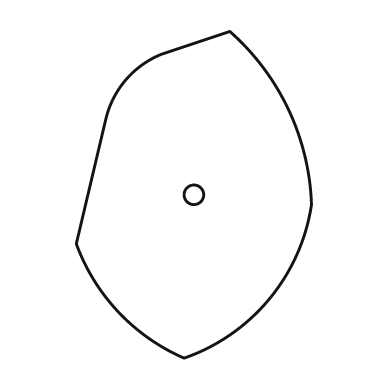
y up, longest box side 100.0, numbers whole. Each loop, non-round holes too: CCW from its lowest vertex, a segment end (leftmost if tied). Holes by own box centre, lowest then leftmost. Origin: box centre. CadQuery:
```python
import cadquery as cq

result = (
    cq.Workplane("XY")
    .moveTo(-3.0, -50.0)
    .threePointArc((23.0, -32.0), (36.0, -3.0))
    .threePointArc((29.0, 26.0), (11.0, 50.0))
    .lineTo(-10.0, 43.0)
    .threePointArc((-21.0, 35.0), (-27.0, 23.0))
    .lineTo(-36.0, -15.0)
    .threePointArc((-23.0, -36.0), (-3.0, -50.0))
    .close()
    .moveTo(0.0, 0.0)
    .circle(3.0)
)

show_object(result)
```